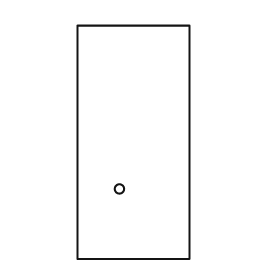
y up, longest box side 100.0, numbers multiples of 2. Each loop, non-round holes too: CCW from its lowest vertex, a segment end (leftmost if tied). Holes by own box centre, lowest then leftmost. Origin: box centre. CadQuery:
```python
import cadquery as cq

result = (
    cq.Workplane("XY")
    .moveTo(-24.0, -50.0)
    .lineTo(24.0, -50.0)
    .lineTo(24.0, 50.0)
    .lineTo(-24.0, 50.0)
    .close()
    .moveTo(-6.0, -20.0)
    .circle(2.0)
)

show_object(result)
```